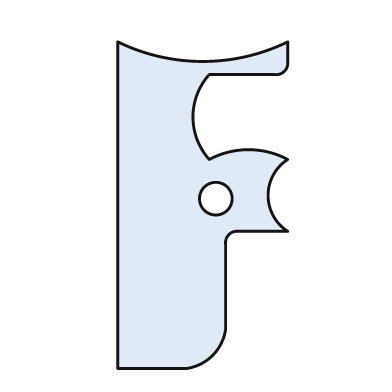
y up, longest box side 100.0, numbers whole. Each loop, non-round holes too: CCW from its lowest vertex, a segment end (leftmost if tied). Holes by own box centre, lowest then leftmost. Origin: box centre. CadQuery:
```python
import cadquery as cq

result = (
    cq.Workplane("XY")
    .moveTo(-26.0, -50.0)
    .lineTo(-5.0, -50.0)
    .threePointArc((3.0, -46.0), (7.0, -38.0))
    .lineTo(7.0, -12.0)
    .threePointArc((8.0, -9.0), (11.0, -8.0))
    .lineTo(26.0, -8.0)
    .threePointArc((20.0, 3.0), (26.0, 14.0))
    .threePointArc((14.0, 17.0), (2.0, 14.0))
    .threePointArc((-3.0, 27.0), (2.0, 40.0))
    .lineTo(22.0, 40.0)
    .threePointArc((25.0, 41.0), (26.0, 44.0))
    .lineTo(26.0, 50.0)
    .threePointArc((0.0, 44.0), (-26.0, 50.0))
    .close()
    .moveTo(4.0, 2.0)
    .circle(5.0)
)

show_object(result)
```